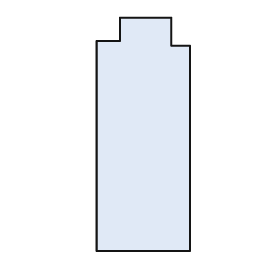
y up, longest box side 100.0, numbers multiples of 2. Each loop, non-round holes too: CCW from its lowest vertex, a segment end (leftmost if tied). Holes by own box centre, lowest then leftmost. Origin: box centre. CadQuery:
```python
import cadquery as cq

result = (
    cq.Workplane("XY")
    .moveTo(-20.0, -50.0)
    .lineTo(20.0, -50.0)
    .lineTo(20.0, 38.0)
    .lineTo(12.0, 38.0)
    .lineTo(12.0, 50.0)
    .lineTo(-10.0, 50.0)
    .lineTo(-10.0, 40.0)
    .lineTo(-20.0, 40.0)
    .close()
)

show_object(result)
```